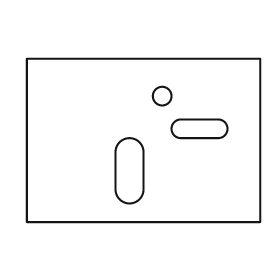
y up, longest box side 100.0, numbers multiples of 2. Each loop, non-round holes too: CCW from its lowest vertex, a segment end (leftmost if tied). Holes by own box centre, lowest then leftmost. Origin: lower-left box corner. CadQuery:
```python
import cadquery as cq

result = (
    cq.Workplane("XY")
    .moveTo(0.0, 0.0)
    .lineTo(100.0, 0.0)
    .lineTo(100.0, 70.0)
    .lineTo(0.0, 70.0)
    .close()
    .moveTo(38.0, 14.0)
    .threePointArc((44.0, 8.0), (50.0, 14.0))
    .lineTo(50.0, 30.0)
    .threePointArc((44.0, 36.0), (38.0, 30.0))
    .close()
    .moveTo(66.0, 36.0)
    .lineTo(82.0, 36.0)
    .threePointArc((86.0, 40.0), (82.0, 44.0))
    .lineTo(66.0, 44.0)
    .threePointArc((62.0, 40.0), (66.0, 36.0))
    .close()
    .moveTo(58.0, 54.0)
    .circle(4.0)
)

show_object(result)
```